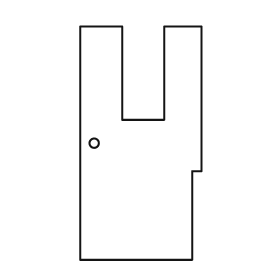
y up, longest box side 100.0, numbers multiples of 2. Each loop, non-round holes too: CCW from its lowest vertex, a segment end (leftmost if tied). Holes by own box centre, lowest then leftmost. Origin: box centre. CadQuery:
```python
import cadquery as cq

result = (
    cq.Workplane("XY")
    .moveTo(-26.0, -50.0)
    .lineTo(22.0, -50.0)
    .lineTo(22.0, -12.0)
    .lineTo(26.0, -12.0)
    .lineTo(26.0, 50.0)
    .lineTo(10.0, 50.0)
    .lineTo(10.0, 10.0)
    .lineTo(-8.0, 10.0)
    .lineTo(-8.0, 50.0)
    .lineTo(-26.0, 50.0)
    .close()
    .moveTo(-20.0, 0.0)
    .circle(2.0)
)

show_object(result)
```